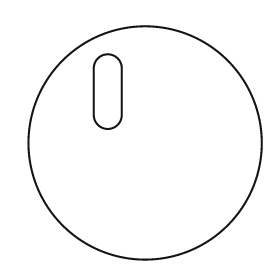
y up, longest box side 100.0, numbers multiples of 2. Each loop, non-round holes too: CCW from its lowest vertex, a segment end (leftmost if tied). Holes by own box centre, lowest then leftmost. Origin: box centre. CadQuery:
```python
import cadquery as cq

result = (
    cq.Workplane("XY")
    .moveTo(0.0, 0.0)
    .circle(50.0)
    .moveTo(-22.0, 12.0)
    .threePointArc((-16.0, 6.0), (-10.0, 12.0))
    .lineTo(-10.0, 32.0)
    .threePointArc((-16.0, 38.0), (-22.0, 32.0))
    .close()
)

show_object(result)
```